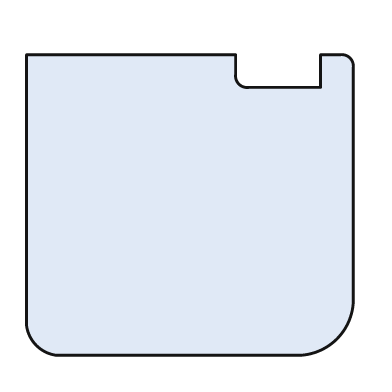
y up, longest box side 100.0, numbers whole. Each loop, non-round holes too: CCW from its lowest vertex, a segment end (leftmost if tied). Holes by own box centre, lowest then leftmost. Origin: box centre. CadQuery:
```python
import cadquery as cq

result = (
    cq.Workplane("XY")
    .moveTo(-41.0, -46.0)
    .lineTo(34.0, -46.0)
    .threePointArc((45.0, -41.0), (50.0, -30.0))
    .lineTo(50.0, 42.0)
    .threePointArc((49.0, 45.0), (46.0, 46.0))
    .lineTo(40.0, 46.0)
    .lineTo(40.0, 36.0)
    .lineTo(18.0, 36.0)
    .threePointArc((15.0, 37.0), (14.0, 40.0))
    .lineTo(14.0, 46.0)
    .lineTo(-50.0, 46.0)
    .lineTo(-50.0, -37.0)
    .threePointArc((-47.0, -43.0), (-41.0, -46.0))
    .close()
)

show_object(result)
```